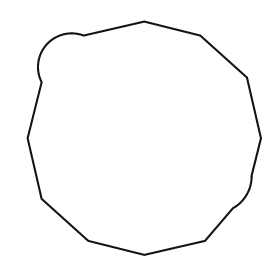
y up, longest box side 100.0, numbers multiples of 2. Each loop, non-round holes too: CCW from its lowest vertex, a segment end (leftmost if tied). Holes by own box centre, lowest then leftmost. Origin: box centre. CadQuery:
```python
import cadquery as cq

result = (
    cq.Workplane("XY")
    .moveTo(0.0, -50.0)
    .lineTo(26.0, -44.0)
    .lineTo(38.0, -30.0)
    .threePointArc((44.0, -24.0), (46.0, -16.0))
    .lineTo(50.0, 0.0)
    .lineTo(44.0, 26.0)
    .lineTo(24.0, 44.0)
    .lineTo(0.0, 50.0)
    .lineTo(-26.0, 44.0)
    .threePointArc((-42.0, 40.0), (-44.0, 24.0))
    .lineTo(-50.0, 0.0)
    .lineTo(-44.0, -26.0)
    .lineTo(-24.0, -44.0)
    .close()
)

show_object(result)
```